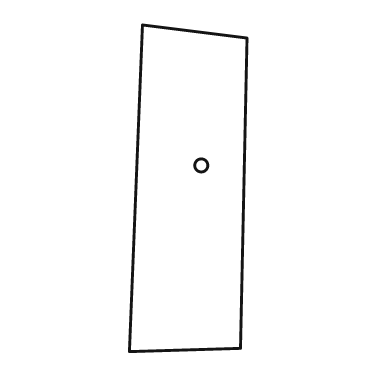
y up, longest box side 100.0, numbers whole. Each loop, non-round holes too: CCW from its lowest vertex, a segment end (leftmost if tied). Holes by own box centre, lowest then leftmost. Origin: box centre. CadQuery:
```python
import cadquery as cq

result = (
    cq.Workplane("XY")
    .moveTo(-18.0, -50.0)
    .lineTo(16.0, -49.0)
    .lineTo(18.0, 46.0)
    .lineTo(-14.0, 50.0)
    .close()
    .moveTo(4.0, 7.0)
    .circle(2.0)
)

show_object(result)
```